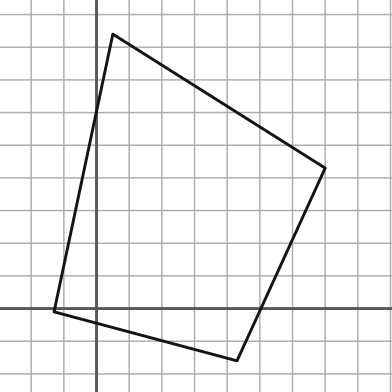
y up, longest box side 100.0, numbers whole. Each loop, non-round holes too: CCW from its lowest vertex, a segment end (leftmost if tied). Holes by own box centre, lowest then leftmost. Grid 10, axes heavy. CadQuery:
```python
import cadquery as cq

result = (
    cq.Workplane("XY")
    .moveTo(43.0, -16.0)
    .lineTo(70.0, 43.0)
    .lineTo(5.0, 84.0)
    .lineTo(-13.0, -1.0)
    .close()
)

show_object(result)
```